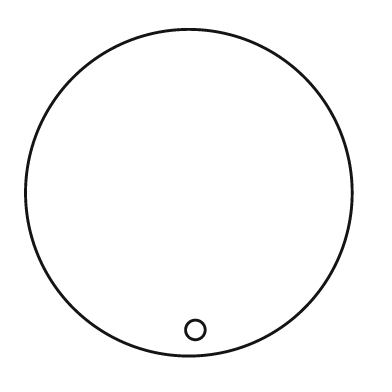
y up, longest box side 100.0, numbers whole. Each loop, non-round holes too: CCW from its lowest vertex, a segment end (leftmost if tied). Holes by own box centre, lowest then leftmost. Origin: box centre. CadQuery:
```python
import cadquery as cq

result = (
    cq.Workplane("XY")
    .moveTo(0.0, 0.0)
    .circle(50.0)
    .moveTo(2.0, -42.0)
    .circle(3.0)
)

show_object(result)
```